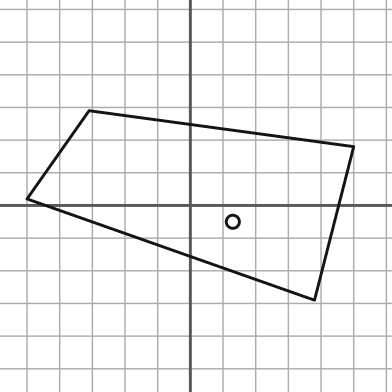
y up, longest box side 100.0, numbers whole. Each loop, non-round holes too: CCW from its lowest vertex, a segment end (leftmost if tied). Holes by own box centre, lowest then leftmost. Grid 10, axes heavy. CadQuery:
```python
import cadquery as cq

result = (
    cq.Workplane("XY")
    .moveTo(38.0, -29.0)
    .lineTo(50.0, 18.0)
    .lineTo(-31.0, 29.0)
    .lineTo(-50.0, 2.0)
    .close()
    .moveTo(13.0, -5.0)
    .circle(2.0)
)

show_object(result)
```